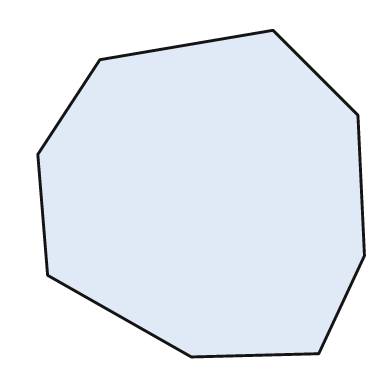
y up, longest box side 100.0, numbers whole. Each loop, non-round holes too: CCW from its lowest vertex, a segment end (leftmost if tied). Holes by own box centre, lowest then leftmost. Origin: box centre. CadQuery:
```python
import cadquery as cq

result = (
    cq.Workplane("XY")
    .moveTo(-3.0, -50.0)
    .lineTo(36.0, -49.0)
    .lineTo(50.0, -19.0)
    .lineTo(48.0, 24.0)
    .lineTo(22.0, 50.0)
    .lineTo(-31.0, 41.0)
    .lineTo(-50.0, 12.0)
    .lineTo(-47.0, -25.0)
    .close()
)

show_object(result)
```